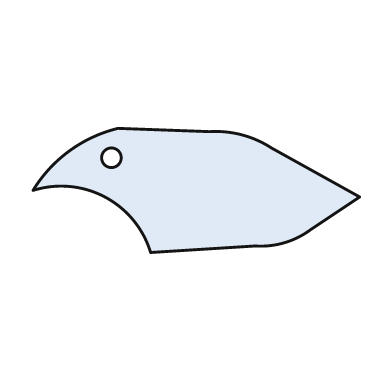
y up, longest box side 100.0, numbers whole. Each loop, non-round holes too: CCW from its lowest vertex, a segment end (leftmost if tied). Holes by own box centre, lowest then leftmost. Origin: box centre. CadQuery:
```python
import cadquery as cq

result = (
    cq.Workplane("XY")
    .moveTo(-14.0, -19.0)
    .lineTo(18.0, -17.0)
    .threePointArc((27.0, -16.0), (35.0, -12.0))
    .lineTo(50.0, -2.0)
    .lineTo(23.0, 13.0)
    .threePointArc((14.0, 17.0), (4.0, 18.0))
    .lineTo(-24.0, 19.0)
    .threePointArc((-39.0, 12.0), (-50.0, 0.0))
    .threePointArc((-28.0, -2.0), (-14.0, -19.0))
    .close()
    .moveTo(-26.0, 10.0)
    .circle(3.0)
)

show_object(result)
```